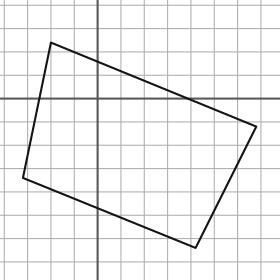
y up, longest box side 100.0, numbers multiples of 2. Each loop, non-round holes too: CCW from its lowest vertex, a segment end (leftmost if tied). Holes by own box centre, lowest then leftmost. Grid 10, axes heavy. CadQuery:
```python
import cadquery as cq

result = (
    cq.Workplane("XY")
    .moveTo(42.0, -64.0)
    .lineTo(68.0, -12.0)
    .lineTo(-20.0, 24.0)
    .lineTo(-32.0, -34.0)
    .close()
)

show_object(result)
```